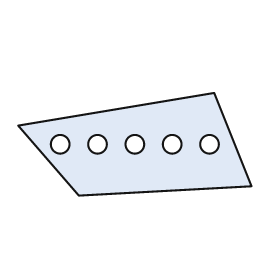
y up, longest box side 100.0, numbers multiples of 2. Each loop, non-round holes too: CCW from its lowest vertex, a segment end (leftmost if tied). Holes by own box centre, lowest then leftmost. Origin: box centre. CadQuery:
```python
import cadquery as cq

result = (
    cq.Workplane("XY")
    .moveTo(-24.0, -22.0)
    .lineTo(50.0, -18.0)
    .lineTo(34.0, 22.0)
    .lineTo(-50.0, 8.0)
    .close()
    .moveTo(-32.0, 0.0)
    .circle(4.0)
    .moveTo(-16.0, 0.0)
    .circle(4.0)
    .moveTo(0.0, 0.0)
    .circle(4.0)
    .moveTo(16.0, 0.0)
    .circle(4.0)
    .moveTo(32.0, 0.0)
    .circle(4.0)
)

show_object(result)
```